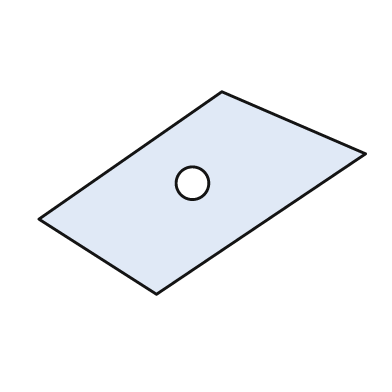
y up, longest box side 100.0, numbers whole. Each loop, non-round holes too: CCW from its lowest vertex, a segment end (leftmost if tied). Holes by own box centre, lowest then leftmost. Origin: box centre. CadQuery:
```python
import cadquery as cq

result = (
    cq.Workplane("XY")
    .moveTo(-14.0, -31.0)
    .lineTo(50.0, 12.0)
    .lineTo(6.0, 31.0)
    .lineTo(-50.0, -8.0)
    .close()
    .moveTo(-3.0, 3.0)
    .circle(5.0)
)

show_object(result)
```